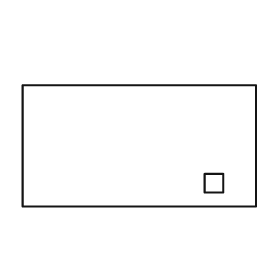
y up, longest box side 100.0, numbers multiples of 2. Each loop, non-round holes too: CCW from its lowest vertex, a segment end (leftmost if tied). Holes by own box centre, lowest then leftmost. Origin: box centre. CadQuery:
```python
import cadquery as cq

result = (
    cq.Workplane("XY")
    .moveTo(-50.0, -26.0)
    .lineTo(50.0, -26.0)
    .lineTo(50.0, 26.0)
    .lineTo(-50.0, 26.0)
    .close()
    .moveTo(28.0, -20.0)
    .lineTo(36.0, -20.0)
    .lineTo(36.0, -12.0)
    .lineTo(28.0, -12.0)
    .close()
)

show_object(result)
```